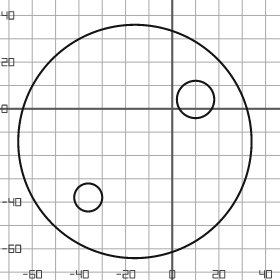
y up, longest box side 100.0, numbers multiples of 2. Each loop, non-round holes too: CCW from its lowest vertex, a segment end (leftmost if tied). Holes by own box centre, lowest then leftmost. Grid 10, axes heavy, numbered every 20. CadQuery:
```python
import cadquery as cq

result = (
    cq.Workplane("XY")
    .moveTo(-16.0, -14.0)
    .circle(50.0)
    .moveTo(-36.0, -38.0)
    .circle(6.0)
    .moveTo(10.0, 4.0)
    .circle(8.0)
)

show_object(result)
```